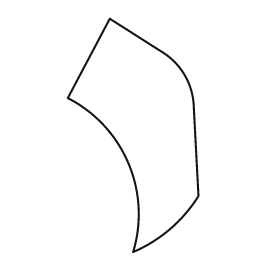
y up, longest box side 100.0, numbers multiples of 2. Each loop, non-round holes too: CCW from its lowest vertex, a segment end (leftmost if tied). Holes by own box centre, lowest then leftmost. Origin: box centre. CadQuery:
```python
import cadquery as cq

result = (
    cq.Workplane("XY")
    .moveTo(0.0, -50.0)
    .threePointArc((16.0, -40.0), (28.0, -26.0))
    .lineTo(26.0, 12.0)
    .threePointArc((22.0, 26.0), (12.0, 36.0))
    .lineTo(-10.0, 50.0)
    .lineTo(-28.0, 16.0)
    .threePointArc((-2.0, -12.0), (0.0, -50.0))
    .close()
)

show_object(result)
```